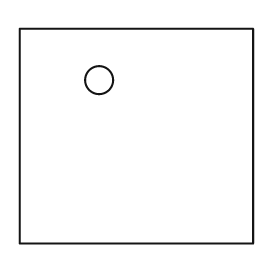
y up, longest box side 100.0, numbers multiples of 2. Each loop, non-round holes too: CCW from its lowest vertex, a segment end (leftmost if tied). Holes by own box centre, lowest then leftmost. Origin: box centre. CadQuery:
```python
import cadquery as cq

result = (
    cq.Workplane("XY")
    .moveTo(-50.0, -46.0)
    .lineTo(50.0, -46.0)
    .lineTo(50.0, 46.0)
    .lineTo(-50.0, 46.0)
    .close()
    .moveTo(-16.0, 24.0)
    .circle(6.0)
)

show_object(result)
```